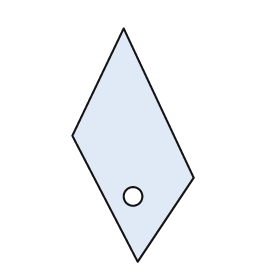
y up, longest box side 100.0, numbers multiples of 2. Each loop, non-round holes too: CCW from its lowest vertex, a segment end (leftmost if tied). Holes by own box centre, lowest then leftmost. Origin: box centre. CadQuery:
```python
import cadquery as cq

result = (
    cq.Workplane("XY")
    .moveTo(2.0, -50.0)
    .lineTo(26.0, -14.0)
    .lineTo(-4.0, 50.0)
    .lineTo(-26.0, 4.0)
    .close()
    .moveTo(0.0, -22.0)
    .circle(4.0)
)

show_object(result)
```